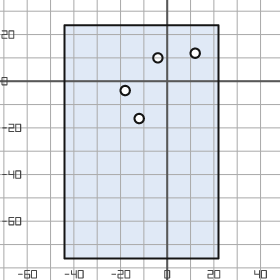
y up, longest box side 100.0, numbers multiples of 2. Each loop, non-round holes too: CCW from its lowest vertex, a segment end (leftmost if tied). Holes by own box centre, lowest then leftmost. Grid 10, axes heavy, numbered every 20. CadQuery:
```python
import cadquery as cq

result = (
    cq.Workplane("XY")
    .moveTo(-44.0, -76.0)
    .lineTo(22.0, -76.0)
    .lineTo(22.0, 24.0)
    .lineTo(-44.0, 24.0)
    .close()
    .moveTo(-12.0, -16.0)
    .circle(2.0)
    .moveTo(-18.0, -4.0)
    .circle(2.0)
    .moveTo(-4.0, 10.0)
    .circle(2.0)
    .moveTo(12.0, 12.0)
    .circle(2.0)
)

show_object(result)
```